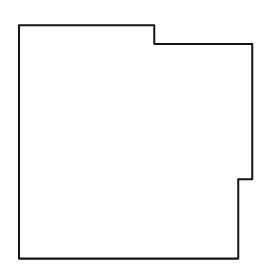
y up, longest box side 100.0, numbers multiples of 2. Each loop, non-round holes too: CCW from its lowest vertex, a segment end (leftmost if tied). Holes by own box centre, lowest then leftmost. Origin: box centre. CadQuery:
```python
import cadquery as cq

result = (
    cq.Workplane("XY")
    .moveTo(-50.0, -50.0)
    .lineTo(44.0, -50.0)
    .lineTo(44.0, -16.0)
    .lineTo(50.0, -16.0)
    .lineTo(50.0, 42.0)
    .lineTo(8.0, 42.0)
    .lineTo(8.0, 50.0)
    .lineTo(-50.0, 50.0)
    .close()
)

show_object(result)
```